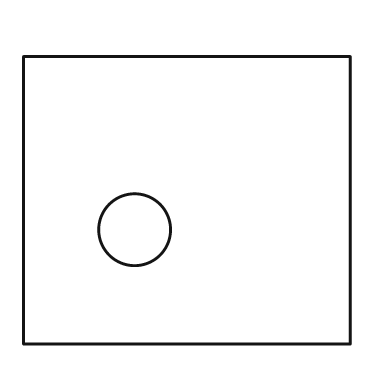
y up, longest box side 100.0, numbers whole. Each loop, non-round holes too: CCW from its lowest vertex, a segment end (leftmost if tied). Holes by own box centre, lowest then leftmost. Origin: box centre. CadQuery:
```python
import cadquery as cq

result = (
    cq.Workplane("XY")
    .moveTo(-50.0, -44.0)
    .lineTo(50.0, -44.0)
    .lineTo(50.0, 44.0)
    .lineTo(-50.0, 44.0)
    .close()
    .moveTo(-16.0, -9.0)
    .circle(11.0)
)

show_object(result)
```